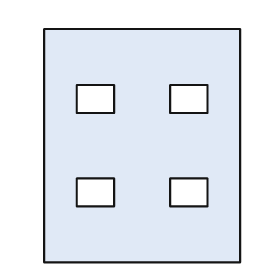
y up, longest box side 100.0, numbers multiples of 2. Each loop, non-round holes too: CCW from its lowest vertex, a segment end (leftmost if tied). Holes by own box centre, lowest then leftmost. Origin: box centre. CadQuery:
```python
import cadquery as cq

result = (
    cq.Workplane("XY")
    .moveTo(-42.0, -50.0)
    .lineTo(42.0, -50.0)
    .lineTo(42.0, 50.0)
    .lineTo(-42.0, 50.0)
    .close()
    .moveTo(-28.0, -26.0)
    .lineTo(-12.0, -26.0)
    .lineTo(-12.0, -14.0)
    .lineTo(-28.0, -14.0)
    .close()
    .moveTo(12.0, -26.0)
    .lineTo(28.0, -26.0)
    .lineTo(28.0, -14.0)
    .lineTo(12.0, -14.0)
    .close()
    .moveTo(-28.0, 14.0)
    .lineTo(-12.0, 14.0)
    .lineTo(-12.0, 26.0)
    .lineTo(-28.0, 26.0)
    .close()
    .moveTo(12.0, 14.0)
    .lineTo(28.0, 14.0)
    .lineTo(28.0, 26.0)
    .lineTo(12.0, 26.0)
    .close()
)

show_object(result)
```